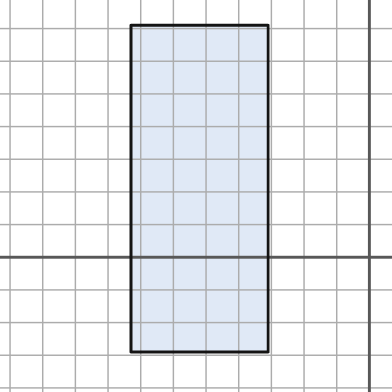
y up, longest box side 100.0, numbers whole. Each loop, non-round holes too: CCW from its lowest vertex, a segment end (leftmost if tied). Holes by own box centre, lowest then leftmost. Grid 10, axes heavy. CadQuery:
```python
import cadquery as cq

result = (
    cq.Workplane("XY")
    .moveTo(-73.0, -29.0)
    .lineTo(-31.0, -29.0)
    .lineTo(-31.0, 71.0)
    .lineTo(-73.0, 71.0)
    .close()
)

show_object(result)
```